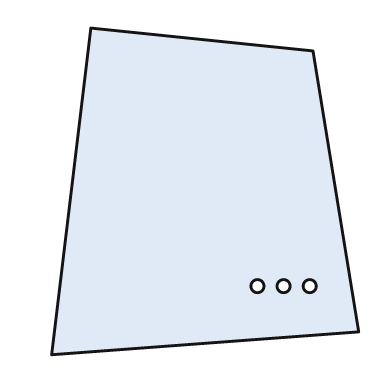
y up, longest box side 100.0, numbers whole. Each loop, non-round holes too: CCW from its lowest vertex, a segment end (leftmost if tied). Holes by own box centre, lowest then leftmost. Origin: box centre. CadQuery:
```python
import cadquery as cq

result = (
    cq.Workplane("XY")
    .moveTo(-47.0, -50.0)
    .lineTo(47.0, -43.0)
    .lineTo(33.0, 43.0)
    .lineTo(-35.0, 50.0)
    .close()
    .moveTo(16.0, -29.0)
    .circle(2.0)
    .moveTo(24.0, -29.0)
    .circle(2.0)
    .moveTo(32.0, -29.0)
    .circle(2.0)
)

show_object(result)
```